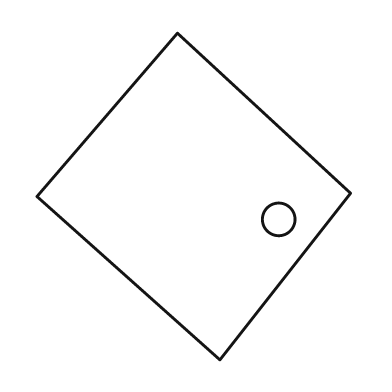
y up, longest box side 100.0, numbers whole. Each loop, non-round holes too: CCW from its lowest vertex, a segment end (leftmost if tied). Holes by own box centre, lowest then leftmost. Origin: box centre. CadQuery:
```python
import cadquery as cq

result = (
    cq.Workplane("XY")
    .moveTo(8.0, -50.0)
    .lineTo(48.0, 1.0)
    .lineTo(-5.0, 50.0)
    .lineTo(-48.0, 0.0)
    .close()
    .moveTo(26.0, -7.0)
    .circle(5.0)
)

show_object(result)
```